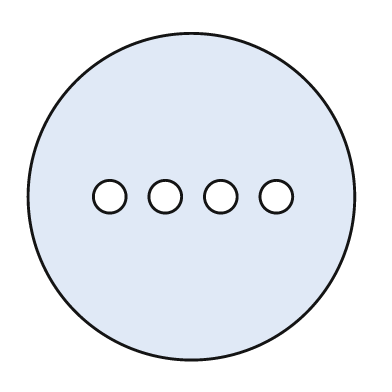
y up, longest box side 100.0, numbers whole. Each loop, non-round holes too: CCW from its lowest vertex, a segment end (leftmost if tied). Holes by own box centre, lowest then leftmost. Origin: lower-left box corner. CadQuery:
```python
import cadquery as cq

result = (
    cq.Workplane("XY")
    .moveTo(50.0, 50.0)
    .circle(50.0)
    .moveTo(25.0, 50.0)
    .circle(5.0)
    .moveTo(42.0, 50.0)
    .circle(5.0)
    .moveTo(59.0, 50.0)
    .circle(5.0)
    .moveTo(76.0, 50.0)
    .circle(5.0)
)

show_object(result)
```